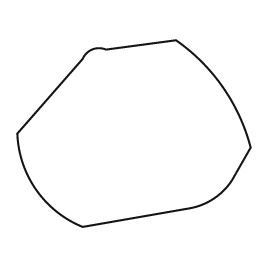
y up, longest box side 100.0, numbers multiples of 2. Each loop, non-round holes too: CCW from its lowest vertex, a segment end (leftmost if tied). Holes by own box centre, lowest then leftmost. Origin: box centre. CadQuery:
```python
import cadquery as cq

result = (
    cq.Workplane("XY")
    .moveTo(-22.0, -40.0)
    .lineTo(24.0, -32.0)
    .threePointArc((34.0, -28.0), (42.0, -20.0))
    .lineTo(50.0, -6.0)
    .threePointArc((38.0, 20.0), (18.0, 40.0))
    .lineTo(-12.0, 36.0)
    .threePointArc((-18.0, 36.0), (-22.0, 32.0))
    .lineTo(-50.0, 0.0)
    .threePointArc((-42.0, -24.0), (-22.0, -40.0))
    .close()
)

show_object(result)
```